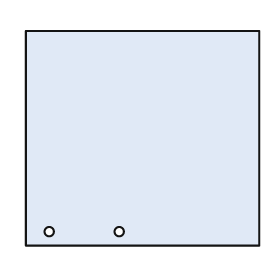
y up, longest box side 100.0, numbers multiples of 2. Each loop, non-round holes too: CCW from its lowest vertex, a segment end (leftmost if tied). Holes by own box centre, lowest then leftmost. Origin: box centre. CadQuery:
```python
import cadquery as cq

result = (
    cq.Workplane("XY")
    .moveTo(-50.0, -46.0)
    .lineTo(50.0, -46.0)
    .lineTo(50.0, 46.0)
    .lineTo(-50.0, 46.0)
    .close()
    .moveTo(-40.0, -40.0)
    .circle(2.0)
    .moveTo(-10.0, -40.0)
    .circle(2.0)
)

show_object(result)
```